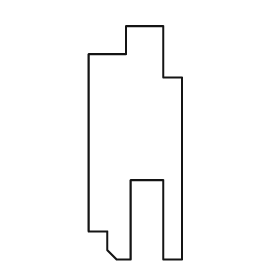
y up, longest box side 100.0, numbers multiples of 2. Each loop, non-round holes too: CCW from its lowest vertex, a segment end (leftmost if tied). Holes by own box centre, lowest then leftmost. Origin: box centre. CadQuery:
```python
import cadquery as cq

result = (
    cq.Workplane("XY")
    .moveTo(-8.0, -50.0)
    .lineTo(-2.0, -50.0)
    .lineTo(-2.0, -16.0)
    .lineTo(12.0, -16.0)
    .lineTo(12.0, -50.0)
    .lineTo(20.0, -50.0)
    .lineTo(20.0, 28.0)
    .lineTo(12.0, 28.0)
    .lineTo(12.0, 50.0)
    .lineTo(-4.0, 50.0)
    .lineTo(-4.0, 38.0)
    .lineTo(-20.0, 38.0)
    .lineTo(-20.0, -38.0)
    .lineTo(-12.0, -38.0)
    .lineTo(-12.0, -46.0)
    .close()
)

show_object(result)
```